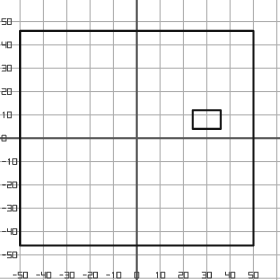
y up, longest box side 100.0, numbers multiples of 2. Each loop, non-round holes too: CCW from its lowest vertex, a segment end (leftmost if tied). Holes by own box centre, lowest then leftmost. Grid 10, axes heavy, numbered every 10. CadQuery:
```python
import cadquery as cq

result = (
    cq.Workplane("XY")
    .moveTo(-50.0, -46.0)
    .lineTo(50.0, -46.0)
    .lineTo(50.0, 46.0)
    .lineTo(-50.0, 46.0)
    .close()
    .moveTo(24.0, 4.0)
    .lineTo(36.0, 4.0)
    .lineTo(36.0, 12.0)
    .lineTo(24.0, 12.0)
    .close()
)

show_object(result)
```